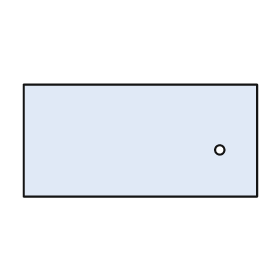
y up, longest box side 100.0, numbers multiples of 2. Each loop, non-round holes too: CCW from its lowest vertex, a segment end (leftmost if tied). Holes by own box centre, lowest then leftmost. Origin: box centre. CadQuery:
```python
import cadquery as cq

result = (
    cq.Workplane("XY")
    .moveTo(-50.0, -24.0)
    .lineTo(50.0, -24.0)
    .lineTo(50.0, 24.0)
    .lineTo(-50.0, 24.0)
    .close()
    .moveTo(34.0, -4.0)
    .circle(2.0)
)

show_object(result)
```